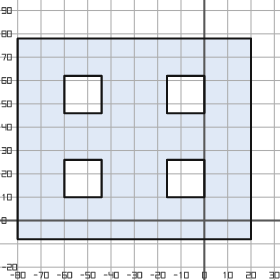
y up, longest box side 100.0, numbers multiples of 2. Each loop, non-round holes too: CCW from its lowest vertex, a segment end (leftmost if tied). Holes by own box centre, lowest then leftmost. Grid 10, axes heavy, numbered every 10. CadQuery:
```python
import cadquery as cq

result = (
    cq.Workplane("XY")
    .moveTo(-80.0, -8.0)
    .lineTo(20.0, -8.0)
    .lineTo(20.0, 78.0)
    .lineTo(-80.0, 78.0)
    .close()
    .moveTo(-60.0, 10.0)
    .lineTo(-44.0, 10.0)
    .lineTo(-44.0, 26.0)
    .lineTo(-60.0, 26.0)
    .close()
    .moveTo(-16.0, 10.0)
    .lineTo(0.0, 10.0)
    .lineTo(0.0, 26.0)
    .lineTo(-16.0, 26.0)
    .close()
    .moveTo(-60.0, 46.0)
    .lineTo(-44.0, 46.0)
    .lineTo(-44.0, 62.0)
    .lineTo(-60.0, 62.0)
    .close()
    .moveTo(-16.0, 46.0)
    .lineTo(0.0, 46.0)
    .lineTo(0.0, 62.0)
    .lineTo(-16.0, 62.0)
    .close()
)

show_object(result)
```